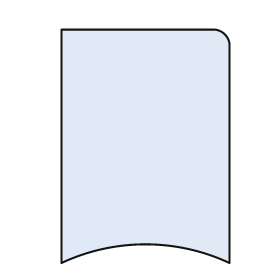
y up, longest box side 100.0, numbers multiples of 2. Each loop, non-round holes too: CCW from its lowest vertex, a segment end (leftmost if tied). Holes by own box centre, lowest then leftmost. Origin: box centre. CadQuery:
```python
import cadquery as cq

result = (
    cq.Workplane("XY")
    .moveTo(-36.0, -50.0)
    .threePointArc((0.0, -42.0), (36.0, -50.0))
    .lineTo(36.0, 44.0)
    .threePointArc((34.0, 48.0), (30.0, 50.0))
    .lineTo(-36.0, 50.0)
    .close()
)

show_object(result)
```